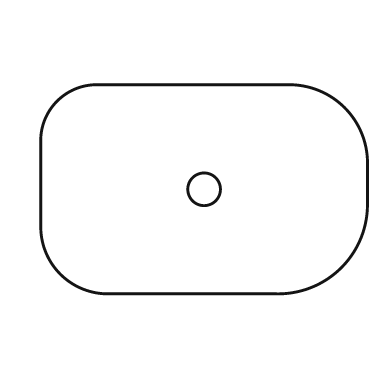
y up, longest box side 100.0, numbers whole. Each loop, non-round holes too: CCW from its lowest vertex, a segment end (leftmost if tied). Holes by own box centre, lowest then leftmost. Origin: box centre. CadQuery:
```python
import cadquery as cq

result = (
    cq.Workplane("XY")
    .moveTo(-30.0, -32.0)
    .lineTo(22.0, -32.0)
    .threePointArc((42.0, -24.0), (50.0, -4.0))
    .lineTo(50.0, 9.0)
    .threePointArc((43.0, 25.0), (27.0, 32.0))
    .lineTo(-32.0, 32.0)
    .threePointArc((-45.0, 27.0), (-50.0, 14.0))
    .lineTo(-50.0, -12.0)
    .threePointArc((-44.0, -26.0), (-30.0, -32.0))
    .close()
    .moveTo(0.0, 0.0)
    .circle(5.0)
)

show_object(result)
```